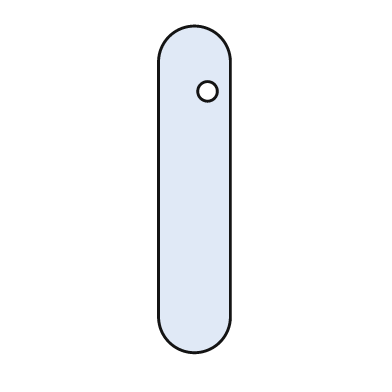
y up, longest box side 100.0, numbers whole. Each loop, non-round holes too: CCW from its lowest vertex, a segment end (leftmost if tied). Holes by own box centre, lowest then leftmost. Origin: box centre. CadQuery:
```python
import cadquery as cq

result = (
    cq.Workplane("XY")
    .moveTo(-11.0, -39.0)
    .threePointArc((0.0, -50.0), (11.0, -39.0))
    .lineTo(11.0, 39.0)
    .threePointArc((0.0, 50.0), (-11.0, 39.0))
    .close()
    .moveTo(4.0, 30.0)
    .circle(3.0)
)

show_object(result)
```